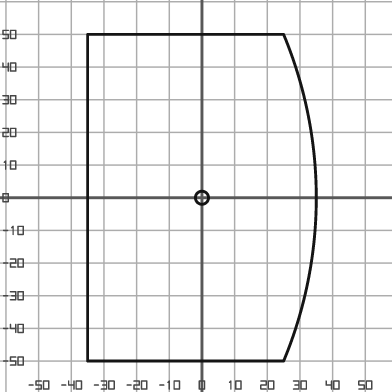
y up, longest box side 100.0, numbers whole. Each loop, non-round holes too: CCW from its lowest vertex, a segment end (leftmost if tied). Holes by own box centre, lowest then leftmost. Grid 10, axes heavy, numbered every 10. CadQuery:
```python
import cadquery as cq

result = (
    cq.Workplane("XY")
    .moveTo(-35.0, -50.0)
    .lineTo(25.0, -50.0)
    .threePointArc((35.0, 0.0), (25.0, 50.0))
    .lineTo(-35.0, 50.0)
    .close()
    .moveTo(0.0, 0.0)
    .circle(2.0)
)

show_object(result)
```